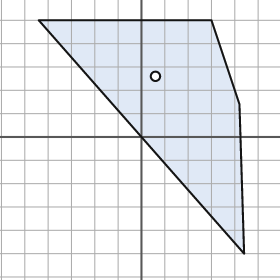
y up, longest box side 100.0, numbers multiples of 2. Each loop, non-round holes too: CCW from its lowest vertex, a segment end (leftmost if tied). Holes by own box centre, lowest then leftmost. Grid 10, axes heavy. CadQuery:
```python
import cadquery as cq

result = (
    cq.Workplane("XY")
    .moveTo(44.0, -50.0)
    .lineTo(42.0, 14.0)
    .lineTo(30.0, 50.0)
    .lineTo(-44.0, 50.0)
    .close()
    .moveTo(6.0, 26.0)
    .circle(2.0)
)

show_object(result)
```